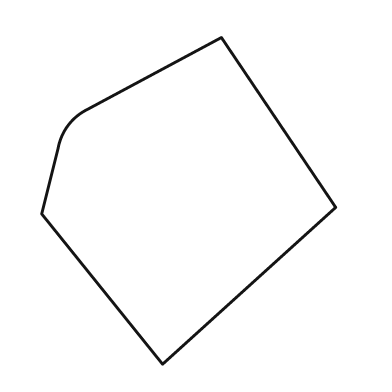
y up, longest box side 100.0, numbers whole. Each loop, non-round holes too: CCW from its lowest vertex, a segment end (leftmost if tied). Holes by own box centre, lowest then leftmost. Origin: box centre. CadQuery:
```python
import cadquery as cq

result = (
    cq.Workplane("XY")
    .moveTo(-8.0, -50.0)
    .lineTo(45.0, -2.0)
    .lineTo(10.0, 50.0)
    .lineTo(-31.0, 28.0)
    .threePointArc((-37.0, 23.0), (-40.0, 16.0))
    .lineTo(-45.0, -4.0)
    .close()
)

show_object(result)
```